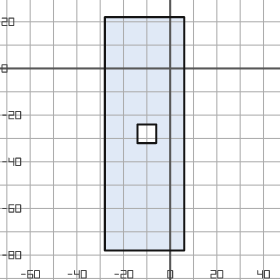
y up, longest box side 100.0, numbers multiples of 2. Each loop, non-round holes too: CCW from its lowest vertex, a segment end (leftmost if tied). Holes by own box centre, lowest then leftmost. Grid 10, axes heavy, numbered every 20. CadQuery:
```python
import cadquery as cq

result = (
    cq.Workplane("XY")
    .moveTo(-28.0, -78.0)
    .lineTo(6.0, -78.0)
    .lineTo(6.0, 22.0)
    .lineTo(-28.0, 22.0)
    .close()
    .moveTo(-14.0, -32.0)
    .lineTo(-6.0, -32.0)
    .lineTo(-6.0, -24.0)
    .lineTo(-14.0, -24.0)
    .close()
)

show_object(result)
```